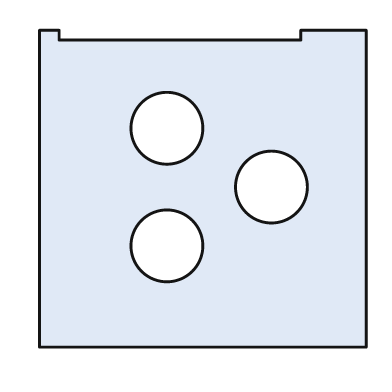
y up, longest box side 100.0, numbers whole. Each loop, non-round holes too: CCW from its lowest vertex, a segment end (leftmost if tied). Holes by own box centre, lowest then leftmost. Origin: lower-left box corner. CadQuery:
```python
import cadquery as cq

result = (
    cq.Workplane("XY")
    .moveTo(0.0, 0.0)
    .lineTo(100.0, 0.0)
    .lineTo(100.0, 97.0)
    .lineTo(80.0, 97.0)
    .lineTo(80.0, 94.0)
    .lineTo(6.0, 94.0)
    .lineTo(6.0, 97.0)
    .lineTo(0.0, 97.0)
    .close()
    .moveTo(39.0, 31.0)
    .circle(11.0)
    .moveTo(71.0, 49.0)
    .circle(11.0)
    .moveTo(39.0, 67.0)
    .circle(11.0)
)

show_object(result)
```